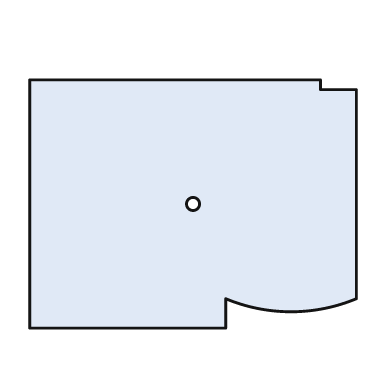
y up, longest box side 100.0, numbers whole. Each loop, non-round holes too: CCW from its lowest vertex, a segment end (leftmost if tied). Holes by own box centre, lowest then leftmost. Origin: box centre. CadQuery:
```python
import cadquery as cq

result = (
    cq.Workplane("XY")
    .moveTo(-50.0, -38.0)
    .lineTo(10.0, -38.0)
    .lineTo(10.0, -29.0)
    .threePointArc((30.0, -33.0), (50.0, -29.0))
    .lineTo(50.0, 35.0)
    .lineTo(39.0, 35.0)
    .lineTo(39.0, 38.0)
    .lineTo(-50.0, 38.0)
    .close()
    .moveTo(0.0, 0.0)
    .circle(2.0)
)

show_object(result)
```